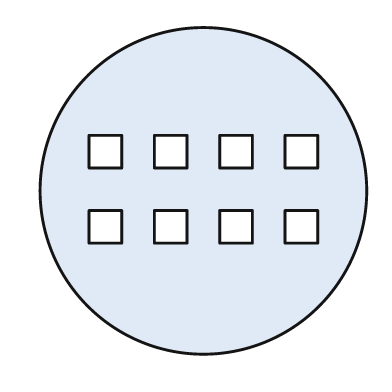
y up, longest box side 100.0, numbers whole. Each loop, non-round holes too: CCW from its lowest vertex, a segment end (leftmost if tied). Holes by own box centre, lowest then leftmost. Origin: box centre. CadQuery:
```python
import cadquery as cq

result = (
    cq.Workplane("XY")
    .moveTo(0.0, 0.0)
    .circle(50.0)
    .moveTo(-35.0, -16.0)
    .lineTo(-25.0, -16.0)
    .lineTo(-25.0, -6.0)
    .lineTo(-35.0, -6.0)
    .close()
    .moveTo(-15.0, -16.0)
    .lineTo(-5.0, -16.0)
    .lineTo(-5.0, -6.0)
    .lineTo(-15.0, -6.0)
    .close()
    .moveTo(5.0, -16.0)
    .lineTo(15.0, -16.0)
    .lineTo(15.0, -6.0)
    .lineTo(5.0, -6.0)
    .close()
    .moveTo(25.0, -16.0)
    .lineTo(35.0, -16.0)
    .lineTo(35.0, -6.0)
    .lineTo(25.0, -6.0)
    .close()
    .moveTo(-35.0, 7.0)
    .lineTo(-25.0, 7.0)
    .lineTo(-25.0, 17.0)
    .lineTo(-35.0, 17.0)
    .close()
    .moveTo(-15.0, 7.0)
    .lineTo(-5.0, 7.0)
    .lineTo(-5.0, 17.0)
    .lineTo(-15.0, 17.0)
    .close()
    .moveTo(5.0, 7.0)
    .lineTo(15.0, 7.0)
    .lineTo(15.0, 17.0)
    .lineTo(5.0, 17.0)
    .close()
    .moveTo(25.0, 7.0)
    .lineTo(35.0, 7.0)
    .lineTo(35.0, 17.0)
    .lineTo(25.0, 17.0)
    .close()
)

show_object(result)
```